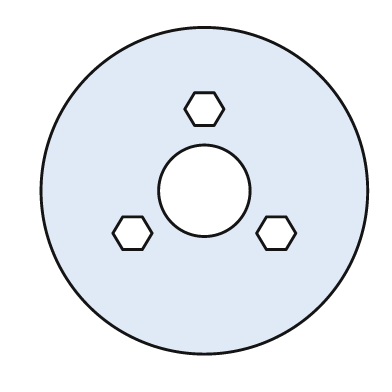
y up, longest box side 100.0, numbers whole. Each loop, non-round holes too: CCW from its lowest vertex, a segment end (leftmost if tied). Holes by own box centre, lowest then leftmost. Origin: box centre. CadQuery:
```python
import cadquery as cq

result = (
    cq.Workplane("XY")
    .moveTo(0.0, 0.0)
    .circle(50.0)
    .moveTo(-25.0, -18.0)
    .lineTo(-19.0, -18.0)
    .lineTo(-16.0, -13.0)
    .lineTo(-19.0, -8.0)
    .lineTo(-25.0, -8.0)
    .lineTo(-28.0, -13.0)
    .close()
    .moveTo(19.0, -18.0)
    .lineTo(25.0, -18.0)
    .lineTo(28.0, -13.0)
    .lineTo(25.0, -8.0)
    .lineTo(19.0, -8.0)
    .lineTo(16.0, -13.0)
    .close()
    .moveTo(0.0, 0.0)
    .circle(14.0)
    .moveTo(-3.0, 20.0)
    .lineTo(3.0, 20.0)
    .lineTo(6.0, 25.0)
    .lineTo(3.0, 30.0)
    .lineTo(-3.0, 30.0)
    .lineTo(-6.0, 25.0)
    .close()
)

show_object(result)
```